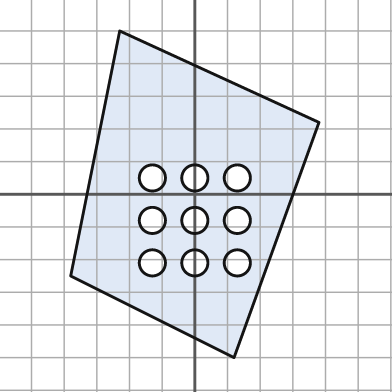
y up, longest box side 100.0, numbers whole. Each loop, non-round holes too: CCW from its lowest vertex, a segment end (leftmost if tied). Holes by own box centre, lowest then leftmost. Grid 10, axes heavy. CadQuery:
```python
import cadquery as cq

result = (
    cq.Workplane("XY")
    .moveTo(12.0, -50.0)
    .lineTo(38.0, 22.0)
    .lineTo(-23.0, 50.0)
    .lineTo(-38.0, -25.0)
    .close()
    .moveTo(-13.0, -21.0)
    .circle(4.0)
    .moveTo(0.0, -21.0)
    .circle(4.0)
    .moveTo(13.0, -21.0)
    .circle(4.0)
    .moveTo(-13.0, -8.0)
    .circle(4.0)
    .moveTo(0.0, -8.0)
    .circle(4.0)
    .moveTo(13.0, -8.0)
    .circle(4.0)
    .moveTo(-13.0, 5.0)
    .circle(4.0)
    .moveTo(0.0, 5.0)
    .circle(4.0)
    .moveTo(13.0, 5.0)
    .circle(4.0)
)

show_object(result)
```